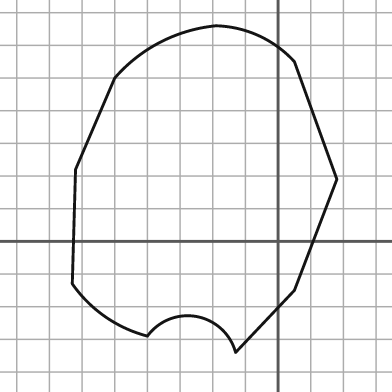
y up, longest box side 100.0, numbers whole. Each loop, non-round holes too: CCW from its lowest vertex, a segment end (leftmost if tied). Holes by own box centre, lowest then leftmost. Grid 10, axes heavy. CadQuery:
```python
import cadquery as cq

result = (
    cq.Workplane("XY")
    .moveTo(-13.0, -34.0)
    .lineTo(5.0, -15.0)
    .lineTo(18.0, 19.0)
    .lineTo(5.0, 55.0)
    .threePointArc((-6.0, 63.0), (-19.0, 66.0))
    .threePointArc((-36.0, 61.0), (-50.0, 50.0))
    .lineTo(-62.0, 22.0)
    .lineTo(-63.0, -13.0)
    .threePointArc((-53.0, -23.0), (-40.0, -29.0))
    .threePointArc((-25.0, -23.0), (-13.0, -34.0))
    .close()
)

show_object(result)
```